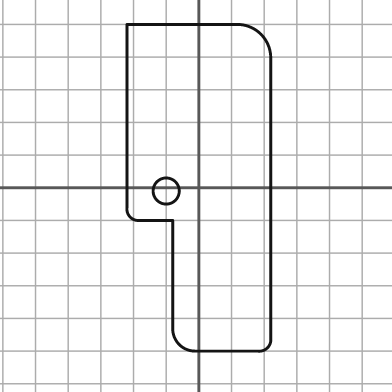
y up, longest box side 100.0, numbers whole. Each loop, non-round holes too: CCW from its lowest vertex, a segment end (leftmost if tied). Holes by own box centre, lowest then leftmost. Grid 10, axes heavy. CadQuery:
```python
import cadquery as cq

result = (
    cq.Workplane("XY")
    .moveTo(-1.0, -50.0)
    .lineTo(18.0, -50.0)
    .threePointArc((21.0, -49.0), (22.0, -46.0))
    .lineTo(22.0, 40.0)
    .threePointArc((19.0, 47.0), (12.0, 50.0))
    .lineTo(-22.0, 50.0)
    .lineTo(-22.0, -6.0)
    .threePointArc((-21.0, -9.0), (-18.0, -10.0))
    .lineTo(-8.0, -10.0)
    .lineTo(-8.0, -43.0)
    .threePointArc((-6.0, -48.0), (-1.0, -50.0))
    .close()
    .moveTo(-10.0, -1.0)
    .circle(4.0)
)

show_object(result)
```